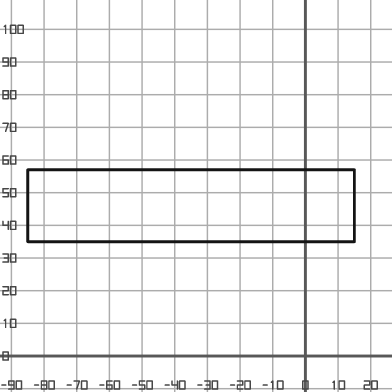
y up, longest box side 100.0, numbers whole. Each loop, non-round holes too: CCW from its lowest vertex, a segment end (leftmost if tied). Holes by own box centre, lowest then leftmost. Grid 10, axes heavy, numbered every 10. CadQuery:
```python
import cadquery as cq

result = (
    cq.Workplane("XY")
    .moveTo(-85.0, 35.0)
    .lineTo(15.0, 35.0)
    .lineTo(15.0, 57.0)
    .lineTo(-85.0, 57.0)
    .close()
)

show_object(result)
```